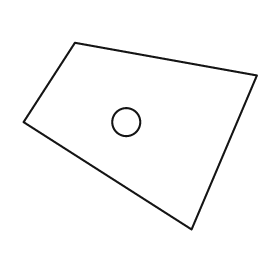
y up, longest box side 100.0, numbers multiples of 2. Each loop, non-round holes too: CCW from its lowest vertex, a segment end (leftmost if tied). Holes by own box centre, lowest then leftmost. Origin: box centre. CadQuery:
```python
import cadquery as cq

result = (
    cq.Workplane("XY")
    .moveTo(22.0, -40.0)
    .lineTo(50.0, 26.0)
    .lineTo(-28.0, 40.0)
    .lineTo(-50.0, 6.0)
    .close()
    .moveTo(-6.0, 6.0)
    .circle(6.0)
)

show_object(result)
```